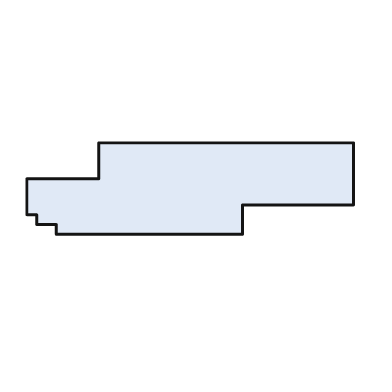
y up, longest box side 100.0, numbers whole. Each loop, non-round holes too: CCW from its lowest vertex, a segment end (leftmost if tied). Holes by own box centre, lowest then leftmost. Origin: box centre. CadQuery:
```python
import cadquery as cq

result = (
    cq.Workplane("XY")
    .moveTo(-41.0, -14.0)
    .lineTo(16.0, -14.0)
    .lineTo(16.0, -5.0)
    .lineTo(50.0, -5.0)
    .lineTo(50.0, 14.0)
    .lineTo(-28.0, 14.0)
    .lineTo(-28.0, 3.0)
    .lineTo(-50.0, 3.0)
    .lineTo(-50.0, -8.0)
    .lineTo(-47.0, -8.0)
    .lineTo(-47.0, -11.0)
    .lineTo(-41.0, -11.0)
    .close()
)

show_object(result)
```